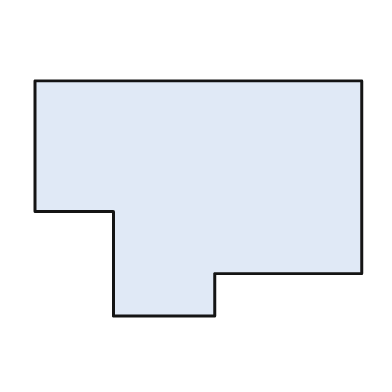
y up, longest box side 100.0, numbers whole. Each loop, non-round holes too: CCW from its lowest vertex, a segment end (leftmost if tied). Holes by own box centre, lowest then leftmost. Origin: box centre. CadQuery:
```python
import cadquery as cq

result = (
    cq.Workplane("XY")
    .moveTo(-26.0, -36.0)
    .lineTo(5.0, -36.0)
    .lineTo(5.0, -23.0)
    .lineTo(50.0, -23.0)
    .lineTo(50.0, 36.0)
    .lineTo(-50.0, 36.0)
    .lineTo(-50.0, -4.0)
    .lineTo(-26.0, -4.0)
    .close()
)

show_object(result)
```